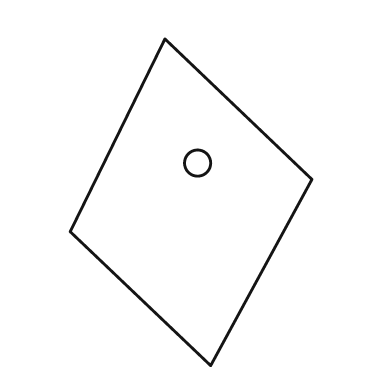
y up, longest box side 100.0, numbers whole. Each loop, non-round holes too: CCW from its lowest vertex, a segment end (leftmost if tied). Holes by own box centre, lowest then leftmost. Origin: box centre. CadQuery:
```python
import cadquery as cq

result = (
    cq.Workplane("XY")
    .moveTo(6.0, -50.0)
    .lineTo(37.0, 7.0)
    .lineTo(-8.0, 50.0)
    .lineTo(-37.0, -9.0)
    .close()
    .moveTo(2.0, 12.0)
    .circle(4.0)
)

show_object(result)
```